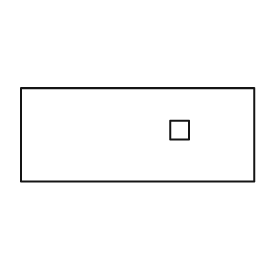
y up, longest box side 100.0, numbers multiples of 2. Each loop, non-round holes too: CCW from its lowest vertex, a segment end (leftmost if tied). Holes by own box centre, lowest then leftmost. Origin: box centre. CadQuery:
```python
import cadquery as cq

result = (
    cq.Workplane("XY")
    .moveTo(-50.0, -20.0)
    .lineTo(50.0, -20.0)
    .lineTo(50.0, 20.0)
    .lineTo(-50.0, 20.0)
    .close()
    .moveTo(14.0, -2.0)
    .lineTo(22.0, -2.0)
    .lineTo(22.0, 6.0)
    .lineTo(14.0, 6.0)
    .close()
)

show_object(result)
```